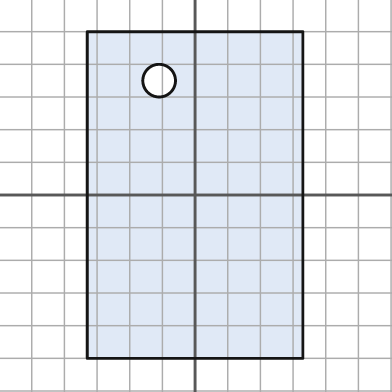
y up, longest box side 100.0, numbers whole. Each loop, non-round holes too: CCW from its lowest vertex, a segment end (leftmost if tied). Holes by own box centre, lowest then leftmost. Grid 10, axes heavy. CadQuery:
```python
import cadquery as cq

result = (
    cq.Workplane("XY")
    .moveTo(-33.0, -50.0)
    .lineTo(33.0, -50.0)
    .lineTo(33.0, 50.0)
    .lineTo(-33.0, 50.0)
    .close()
    .moveTo(-11.0, 35.0)
    .circle(5.0)
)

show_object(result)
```